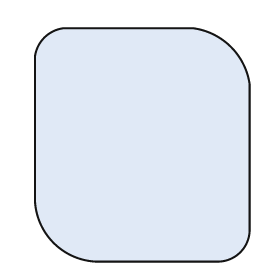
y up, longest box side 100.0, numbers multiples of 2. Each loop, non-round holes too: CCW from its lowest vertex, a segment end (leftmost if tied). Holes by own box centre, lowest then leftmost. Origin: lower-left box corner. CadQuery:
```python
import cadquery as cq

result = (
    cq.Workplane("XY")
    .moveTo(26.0, 0.0)
    .lineTo(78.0, 0.0)
    .threePointArc((88.0, 4.0), (92.0, 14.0))
    .lineTo(92.0, 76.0)
    .threePointArc((84.0, 92.0), (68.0, 100.0))
    .lineTo(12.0, 100.0)
    .threePointArc((4.0, 96.0), (0.0, 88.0))
    .lineTo(0.0, 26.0)
    .threePointArc((8.0, 8.0), (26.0, 0.0))
    .close()
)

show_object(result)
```